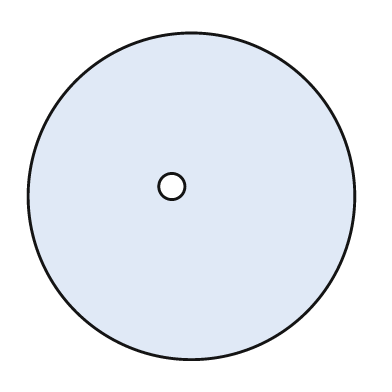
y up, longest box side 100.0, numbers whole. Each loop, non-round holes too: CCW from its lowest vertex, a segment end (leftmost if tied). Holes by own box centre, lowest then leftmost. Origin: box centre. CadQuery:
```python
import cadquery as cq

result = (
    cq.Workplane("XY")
    .moveTo(0.0, 0.0)
    .circle(50.0)
    .moveTo(-6.0, 3.0)
    .circle(4.0)
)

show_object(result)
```